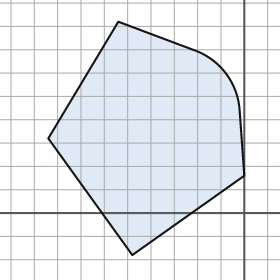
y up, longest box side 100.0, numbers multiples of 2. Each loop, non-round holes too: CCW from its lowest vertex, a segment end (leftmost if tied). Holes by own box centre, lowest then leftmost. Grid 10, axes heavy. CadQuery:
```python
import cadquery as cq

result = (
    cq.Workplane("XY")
    .moveTo(-48.0, -18.0)
    .lineTo(0.0, 16.0)
    .lineTo(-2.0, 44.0)
    .threePointArc((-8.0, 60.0), (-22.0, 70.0))
    .lineTo(-54.0, 82.0)
    .lineTo(-84.0, 32.0)
    .close()
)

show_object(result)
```